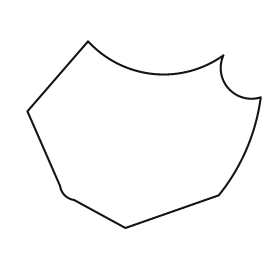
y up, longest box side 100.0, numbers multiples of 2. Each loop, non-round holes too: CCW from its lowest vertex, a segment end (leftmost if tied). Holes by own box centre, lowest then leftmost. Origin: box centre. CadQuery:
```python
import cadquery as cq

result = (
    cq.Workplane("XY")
    .moveTo(-8.0, -40.0)
    .lineTo(32.0, -26.0)
    .threePointArc((44.0, -6.0), (50.0, 16.0))
    .threePointArc((36.0, 20.0), (34.0, 34.0))
    .threePointArc((4.0, 26.0), (-24.0, 40.0))
    .lineTo(-50.0, 10.0)
    .lineTo(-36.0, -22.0)
    .threePointArc((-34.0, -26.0), (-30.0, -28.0))
    .close()
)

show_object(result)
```